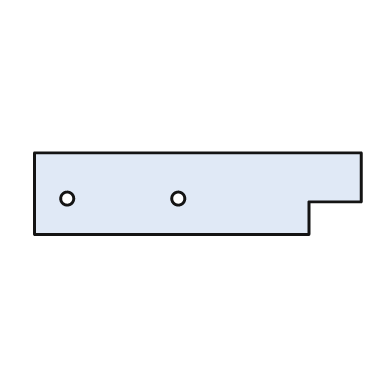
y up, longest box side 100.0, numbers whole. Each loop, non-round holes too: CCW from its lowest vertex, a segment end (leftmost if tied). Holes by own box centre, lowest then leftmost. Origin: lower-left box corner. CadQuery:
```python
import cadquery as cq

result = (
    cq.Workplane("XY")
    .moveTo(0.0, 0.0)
    .lineTo(84.0, 0.0)
    .lineTo(84.0, 10.0)
    .lineTo(100.0, 10.0)
    .lineTo(100.0, 25.0)
    .lineTo(0.0, 25.0)
    .close()
    .moveTo(10.0, 11.0)
    .circle(2.0)
    .moveTo(44.0, 11.0)
    .circle(2.0)
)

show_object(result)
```